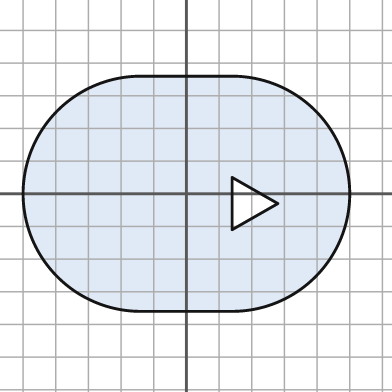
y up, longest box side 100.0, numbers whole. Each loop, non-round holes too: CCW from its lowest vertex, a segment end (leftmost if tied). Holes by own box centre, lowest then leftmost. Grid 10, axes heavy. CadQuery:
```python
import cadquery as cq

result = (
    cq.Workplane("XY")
    .moveTo(-14.0, -36.0)
    .lineTo(14.0, -36.0)
    .threePointArc((50.0, 0.0), (14.0, 36.0))
    .lineTo(-14.0, 36.0)
    .threePointArc((-50.0, 0.0), (-14.0, -36.0))
    .close()
    .moveTo(14.0, -11.0)
    .lineTo(28.0, -3.0)
    .lineTo(14.0, 5.0)
    .close()
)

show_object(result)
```